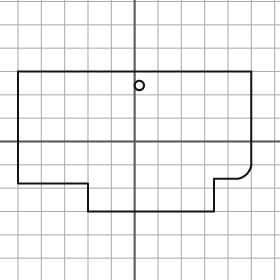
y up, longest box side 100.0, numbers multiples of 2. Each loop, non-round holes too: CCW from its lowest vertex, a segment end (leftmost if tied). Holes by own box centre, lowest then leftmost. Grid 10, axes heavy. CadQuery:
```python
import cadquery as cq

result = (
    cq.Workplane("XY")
    .moveTo(-20.0, -30.0)
    .lineTo(34.0, -30.0)
    .lineTo(34.0, -16.0)
    .lineTo(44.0, -16.0)
    .threePointArc((48.0, -14.0), (50.0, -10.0))
    .lineTo(50.0, 30.0)
    .lineTo(-50.0, 30.0)
    .lineTo(-50.0, -18.0)
    .lineTo(-20.0, -18.0)
    .close()
    .moveTo(2.0, 24.0)
    .circle(2.0)
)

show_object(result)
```